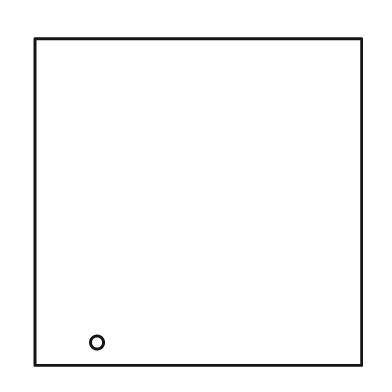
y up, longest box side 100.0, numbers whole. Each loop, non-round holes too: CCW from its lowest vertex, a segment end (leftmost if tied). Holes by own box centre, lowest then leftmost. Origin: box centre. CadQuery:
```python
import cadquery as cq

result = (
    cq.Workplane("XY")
    .moveTo(-50.0, -50.0)
    .lineTo(50.0, -50.0)
    .lineTo(50.0, 50.0)
    .lineTo(-50.0, 50.0)
    .close()
    .moveTo(-31.0, -43.0)
    .circle(2.0)
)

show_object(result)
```